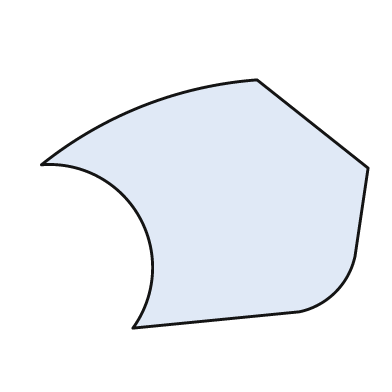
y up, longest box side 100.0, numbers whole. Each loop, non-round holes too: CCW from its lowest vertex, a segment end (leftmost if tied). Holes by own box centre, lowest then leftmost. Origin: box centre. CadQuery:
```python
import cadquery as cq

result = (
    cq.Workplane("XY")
    .moveTo(-22.0, -38.0)
    .lineTo(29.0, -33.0)
    .threePointArc((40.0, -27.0), (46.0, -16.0))
    .lineTo(50.0, 11.0)
    .lineTo(16.0, 38.0)
    .threePointArc((-19.0, 30.0), (-50.0, 12.0))
    .threePointArc((-20.0, -4.0), (-22.0, -38.0))
    .close()
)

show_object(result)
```